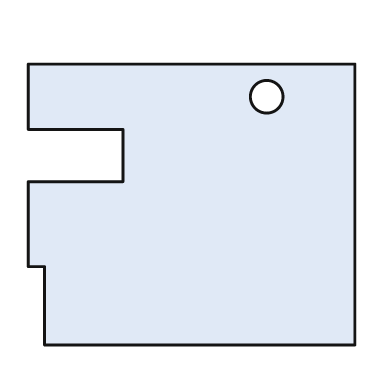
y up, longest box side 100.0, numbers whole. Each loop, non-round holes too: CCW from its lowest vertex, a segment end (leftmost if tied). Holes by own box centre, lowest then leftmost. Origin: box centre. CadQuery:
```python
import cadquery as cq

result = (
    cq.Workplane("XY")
    .moveTo(-45.0, -43.0)
    .lineTo(50.0, -43.0)
    .lineTo(50.0, 43.0)
    .lineTo(-50.0, 43.0)
    .lineTo(-50.0, 23.0)
    .lineTo(-21.0, 23.0)
    .lineTo(-21.0, 7.0)
    .lineTo(-50.0, 7.0)
    .lineTo(-50.0, -19.0)
    .lineTo(-45.0, -19.0)
    .close()
    .moveTo(23.0, 33.0)
    .circle(5.0)
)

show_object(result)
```